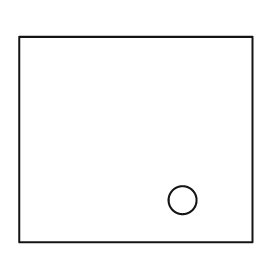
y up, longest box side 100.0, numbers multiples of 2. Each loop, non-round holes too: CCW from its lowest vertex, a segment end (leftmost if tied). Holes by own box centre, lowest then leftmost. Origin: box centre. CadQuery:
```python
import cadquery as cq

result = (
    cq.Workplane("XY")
    .moveTo(-50.0, -44.0)
    .lineTo(50.0, -44.0)
    .lineTo(50.0, 44.0)
    .lineTo(-50.0, 44.0)
    .close()
    .moveTo(20.0, -26.0)
    .circle(6.0)
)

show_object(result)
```